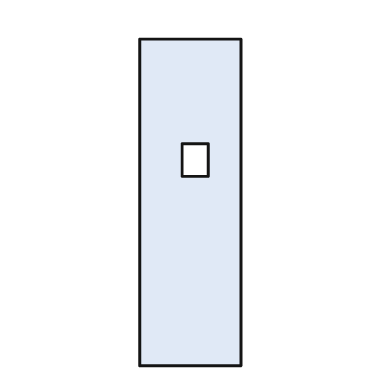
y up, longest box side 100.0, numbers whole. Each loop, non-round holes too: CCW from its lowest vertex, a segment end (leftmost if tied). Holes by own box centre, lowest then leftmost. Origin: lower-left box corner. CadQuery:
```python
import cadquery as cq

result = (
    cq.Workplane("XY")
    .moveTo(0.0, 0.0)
    .lineTo(31.0, 0.0)
    .lineTo(31.0, 100.0)
    .lineTo(0.0, 100.0)
    .close()
    .moveTo(13.0, 58.0)
    .lineTo(21.0, 58.0)
    .lineTo(21.0, 68.0)
    .lineTo(13.0, 68.0)
    .close()
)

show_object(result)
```